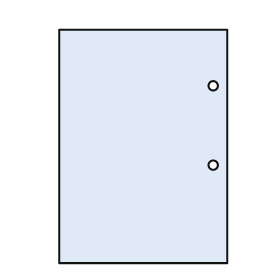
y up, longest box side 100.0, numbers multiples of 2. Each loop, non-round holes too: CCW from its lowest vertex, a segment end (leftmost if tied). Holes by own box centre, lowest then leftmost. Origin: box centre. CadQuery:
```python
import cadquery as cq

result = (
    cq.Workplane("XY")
    .moveTo(-36.0, -50.0)
    .lineTo(36.0, -50.0)
    .lineTo(36.0, 50.0)
    .lineTo(-36.0, 50.0)
    .close()
    .moveTo(30.0, -8.0)
    .circle(2.0)
    .moveTo(30.0, 26.0)
    .circle(2.0)
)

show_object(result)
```